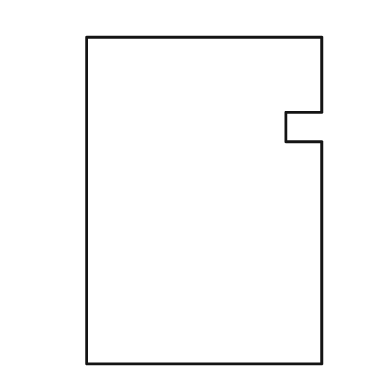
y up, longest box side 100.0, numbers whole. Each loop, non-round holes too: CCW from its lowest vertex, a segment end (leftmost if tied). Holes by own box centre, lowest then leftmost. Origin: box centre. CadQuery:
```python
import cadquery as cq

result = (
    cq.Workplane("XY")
    .moveTo(-36.0, -50.0)
    .lineTo(36.0, -50.0)
    .lineTo(36.0, 18.0)
    .lineTo(25.0, 18.0)
    .lineTo(25.0, 27.0)
    .lineTo(36.0, 27.0)
    .lineTo(36.0, 50.0)
    .lineTo(-36.0, 50.0)
    .close()
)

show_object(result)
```